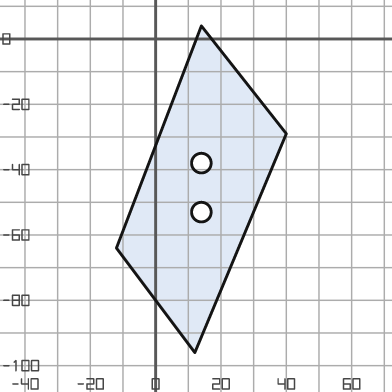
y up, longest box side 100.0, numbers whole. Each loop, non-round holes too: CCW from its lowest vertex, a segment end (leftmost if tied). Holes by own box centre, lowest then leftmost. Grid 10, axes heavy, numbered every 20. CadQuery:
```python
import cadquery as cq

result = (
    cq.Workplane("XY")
    .moveTo(12.0, -96.0)
    .lineTo(40.0, -29.0)
    .lineTo(14.0, 4.0)
    .lineTo(-12.0, -64.0)
    .close()
    .moveTo(14.0, -53.0)
    .circle(3.0)
    .moveTo(14.0, -38.0)
    .circle(3.0)
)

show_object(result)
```